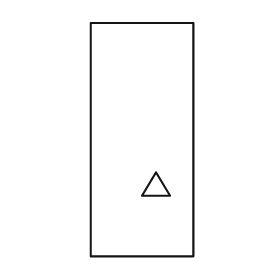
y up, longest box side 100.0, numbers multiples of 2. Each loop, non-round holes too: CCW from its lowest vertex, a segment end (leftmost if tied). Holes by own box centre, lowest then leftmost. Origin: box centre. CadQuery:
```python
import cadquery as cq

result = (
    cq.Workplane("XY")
    .moveTo(-22.0, -50.0)
    .lineTo(22.0, -50.0)
    .lineTo(22.0, 50.0)
    .lineTo(-22.0, 50.0)
    .close()
    .moveTo(0.0, -24.0)
    .lineTo(12.0, -24.0)
    .lineTo(6.0, -14.0)
    .close()
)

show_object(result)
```